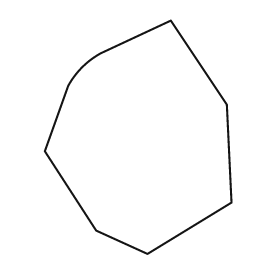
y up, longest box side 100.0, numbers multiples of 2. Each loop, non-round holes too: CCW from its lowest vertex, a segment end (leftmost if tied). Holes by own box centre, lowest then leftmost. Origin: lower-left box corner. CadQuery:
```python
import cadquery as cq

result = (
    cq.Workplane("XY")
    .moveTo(44.0, 0.0)
    .lineTo(80.0, 22.0)
    .lineTo(78.0, 64.0)
    .lineTo(54.0, 100.0)
    .lineTo(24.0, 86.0)
    .threePointArc((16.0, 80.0), (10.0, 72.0))
    .lineTo(0.0, 44.0)
    .lineTo(22.0, 10.0)
    .close()
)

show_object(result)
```